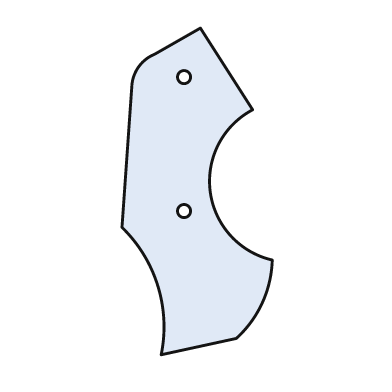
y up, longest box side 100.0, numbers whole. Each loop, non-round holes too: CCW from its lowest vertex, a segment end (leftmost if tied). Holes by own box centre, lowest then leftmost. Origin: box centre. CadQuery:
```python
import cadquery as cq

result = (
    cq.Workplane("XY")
    .moveTo(-11.0, -50.0)
    .lineTo(12.0, -45.0)
    .threePointArc((20.0, -34.0), (23.0, -21.0))
    .threePointArc((4.0, 0.0), (17.0, 25.0))
    .lineTo(1.0, 50.0)
    .lineTo(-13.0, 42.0)
    .threePointArc((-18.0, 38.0), (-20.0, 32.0))
    .lineTo(-23.0, -11.0)
    .threePointArc((-12.0, -29.0), (-11.0, -50.0))
    .close()
    .moveTo(-4.0, -6.0)
    .circle(2.0)
    .moveTo(-4.0, 35.0)
    .circle(2.0)
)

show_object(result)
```